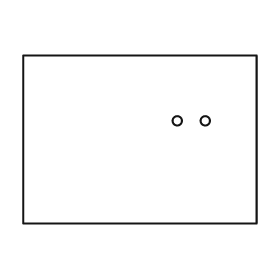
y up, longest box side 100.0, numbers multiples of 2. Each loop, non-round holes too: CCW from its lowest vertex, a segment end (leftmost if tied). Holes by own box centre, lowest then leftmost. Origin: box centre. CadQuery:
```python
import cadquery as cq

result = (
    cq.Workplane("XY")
    .moveTo(-50.0, -36.0)
    .lineTo(50.0, -36.0)
    .lineTo(50.0, 36.0)
    .lineTo(-50.0, 36.0)
    .close()
    .moveTo(16.0, 8.0)
    .circle(2.0)
    .moveTo(28.0, 8.0)
    .circle(2.0)
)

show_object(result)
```